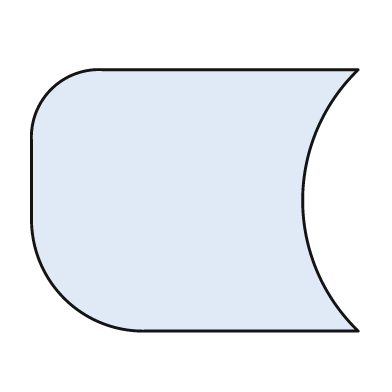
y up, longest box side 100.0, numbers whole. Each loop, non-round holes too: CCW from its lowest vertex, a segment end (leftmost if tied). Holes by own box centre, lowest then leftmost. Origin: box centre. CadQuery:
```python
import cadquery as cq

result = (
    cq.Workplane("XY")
    .moveTo(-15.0, -40.0)
    .lineTo(50.0, -40.0)
    .threePointArc((33.0, 0.0), (50.0, 40.0))
    .lineTo(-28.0, 40.0)
    .threePointArc((-44.0, 34.0), (-50.0, 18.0))
    .lineTo(-50.0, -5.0)
    .threePointArc((-40.0, -30.0), (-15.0, -40.0))
    .close()
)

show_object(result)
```